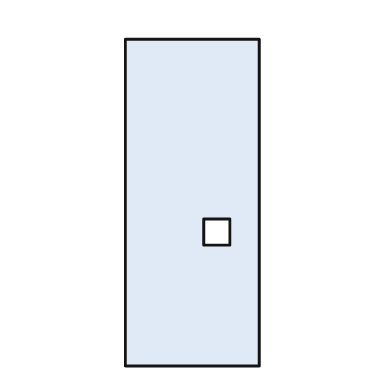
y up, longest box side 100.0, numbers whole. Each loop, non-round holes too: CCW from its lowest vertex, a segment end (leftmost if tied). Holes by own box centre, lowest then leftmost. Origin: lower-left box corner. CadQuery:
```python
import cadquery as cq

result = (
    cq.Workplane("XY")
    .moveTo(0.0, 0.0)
    .lineTo(41.0, 0.0)
    .lineTo(41.0, 100.0)
    .lineTo(0.0, 100.0)
    .close()
    .moveTo(24.0, 37.0)
    .lineTo(32.0, 37.0)
    .lineTo(32.0, 45.0)
    .lineTo(24.0, 45.0)
    .close()
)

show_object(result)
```